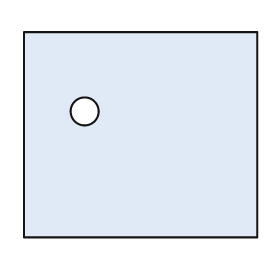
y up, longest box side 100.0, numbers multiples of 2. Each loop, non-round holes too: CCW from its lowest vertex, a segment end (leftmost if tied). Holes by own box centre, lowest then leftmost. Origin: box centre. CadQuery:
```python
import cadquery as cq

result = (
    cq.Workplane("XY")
    .moveTo(-50.0, -44.0)
    .lineTo(50.0, -44.0)
    .lineTo(50.0, 44.0)
    .lineTo(-50.0, 44.0)
    .close()
    .moveTo(-24.0, 10.0)
    .circle(6.0)
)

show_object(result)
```